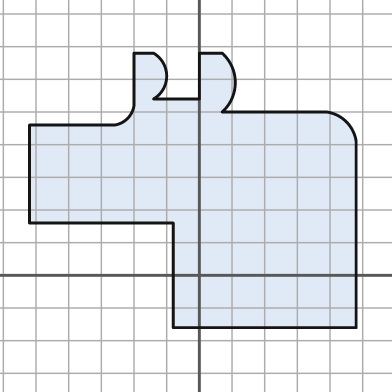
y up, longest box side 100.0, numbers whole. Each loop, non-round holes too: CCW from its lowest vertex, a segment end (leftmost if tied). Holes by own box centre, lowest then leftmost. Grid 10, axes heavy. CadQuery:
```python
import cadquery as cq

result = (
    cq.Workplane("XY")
    .moveTo(-8.0, -16.0)
    .lineTo(48.0, -16.0)
    .lineTo(48.0, 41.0)
    .threePointArc((45.0, 47.0), (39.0, 50.0))
    .lineTo(7.0, 50.0)
    .threePointArc((11.0, 59.0), (7.0, 68.0))
    .lineTo(0.0, 68.0)
    .lineTo(0.0, 54.0)
    .lineTo(-14.0, 54.0)
    .threePointArc((-10.0, 61.0), (-14.0, 68.0))
    .lineTo(-20.0, 68.0)
    .lineTo(-20.0, 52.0)
    .threePointArc((-22.0, 48.0), (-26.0, 46.0))
    .lineTo(-52.0, 46.0)
    .lineTo(-52.0, 16.0)
    .lineTo(-8.0, 16.0)
    .close()
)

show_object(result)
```